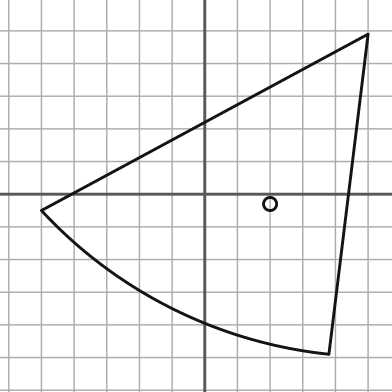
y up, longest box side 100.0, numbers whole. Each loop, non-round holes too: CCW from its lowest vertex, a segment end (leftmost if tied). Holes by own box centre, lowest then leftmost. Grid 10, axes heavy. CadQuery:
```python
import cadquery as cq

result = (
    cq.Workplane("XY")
    .moveTo(38.0, -49.0)
    .lineTo(50.0, 49.0)
    .lineTo(-50.0, -5.0)
    .threePointArc((-10.0, -35.0), (38.0, -49.0))
    .close()
    .moveTo(20.0, -3.0)
    .circle(2.0)
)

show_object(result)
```